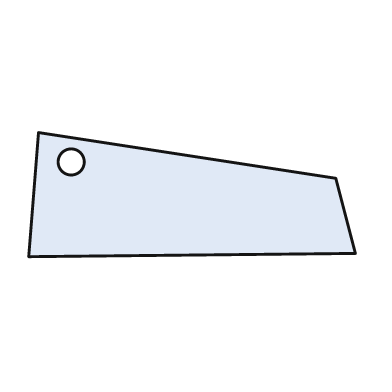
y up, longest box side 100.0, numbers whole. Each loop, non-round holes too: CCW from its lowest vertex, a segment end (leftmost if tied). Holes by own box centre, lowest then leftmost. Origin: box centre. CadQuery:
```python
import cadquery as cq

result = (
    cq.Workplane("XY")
    .moveTo(-50.0, -19.0)
    .lineTo(50.0, -18.0)
    .lineTo(44.0, 5.0)
    .lineTo(-47.0, 19.0)
    .close()
    .moveTo(-37.0, 10.0)
    .circle(4.0)
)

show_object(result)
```